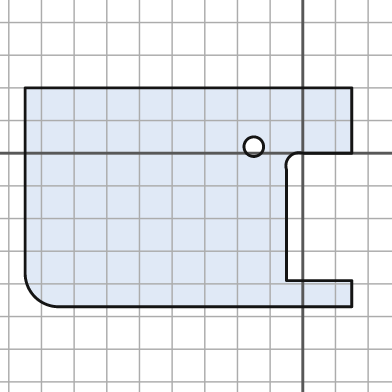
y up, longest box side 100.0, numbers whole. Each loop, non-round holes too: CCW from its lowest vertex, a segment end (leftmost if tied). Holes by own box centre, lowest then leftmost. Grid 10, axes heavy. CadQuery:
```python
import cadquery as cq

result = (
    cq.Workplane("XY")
    .moveTo(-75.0, -47.0)
    .lineTo(15.0, -47.0)
    .lineTo(15.0, -39.0)
    .lineTo(-5.0, -39.0)
    .lineTo(-5.0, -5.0)
    .threePointArc((-4.0, -1.0), (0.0, 0.0))
    .lineTo(15.0, 0.0)
    .lineTo(15.0, 20.0)
    .lineTo(-85.0, 20.0)
    .lineTo(-85.0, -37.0)
    .threePointArc((-82.0, -44.0), (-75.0, -47.0))
    .close()
    .moveTo(-15.0, 2.0)
    .circle(3.0)
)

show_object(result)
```